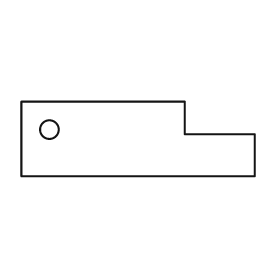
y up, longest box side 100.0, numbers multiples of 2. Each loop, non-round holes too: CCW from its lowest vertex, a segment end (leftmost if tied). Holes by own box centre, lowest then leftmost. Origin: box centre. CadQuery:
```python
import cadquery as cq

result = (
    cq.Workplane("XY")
    .moveTo(-50.0, -16.0)
    .lineTo(50.0, -16.0)
    .lineTo(50.0, 2.0)
    .lineTo(20.0, 2.0)
    .lineTo(20.0, 16.0)
    .lineTo(-50.0, 16.0)
    .close()
    .moveTo(-38.0, 4.0)
    .circle(4.0)
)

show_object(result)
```